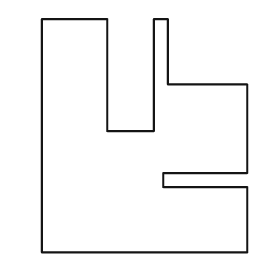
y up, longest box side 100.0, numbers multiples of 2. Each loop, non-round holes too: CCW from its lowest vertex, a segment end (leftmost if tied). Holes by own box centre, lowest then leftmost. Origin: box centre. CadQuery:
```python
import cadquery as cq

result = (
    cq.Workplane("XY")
    .moveTo(-44.0, -50.0)
    .lineTo(44.0, -50.0)
    .lineTo(44.0, -22.0)
    .lineTo(8.0, -22.0)
    .lineTo(8.0, -16.0)
    .lineTo(44.0, -16.0)
    .lineTo(44.0, 22.0)
    .lineTo(10.0, 22.0)
    .lineTo(10.0, 50.0)
    .lineTo(4.0, 50.0)
    .lineTo(4.0, 2.0)
    .lineTo(-16.0, 2.0)
    .lineTo(-16.0, 50.0)
    .lineTo(-44.0, 50.0)
    .close()
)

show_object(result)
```